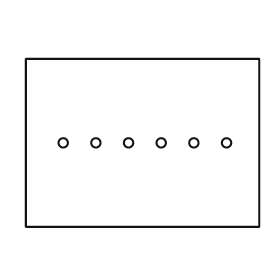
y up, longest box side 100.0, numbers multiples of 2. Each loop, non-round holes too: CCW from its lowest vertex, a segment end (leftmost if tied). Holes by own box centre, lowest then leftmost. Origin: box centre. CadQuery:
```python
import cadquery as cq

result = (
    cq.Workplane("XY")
    .moveTo(-50.0, -36.0)
    .lineTo(50.0, -36.0)
    .lineTo(50.0, 36.0)
    .lineTo(-50.0, 36.0)
    .close()
    .moveTo(-34.0, 0.0)
    .circle(2.0)
    .moveTo(-20.0, 0.0)
    .circle(2.0)
    .moveTo(-6.0, 0.0)
    .circle(2.0)
    .moveTo(8.0, 0.0)
    .circle(2.0)
    .moveTo(22.0, 0.0)
    .circle(2.0)
    .moveTo(36.0, 0.0)
    .circle(2.0)
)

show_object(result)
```